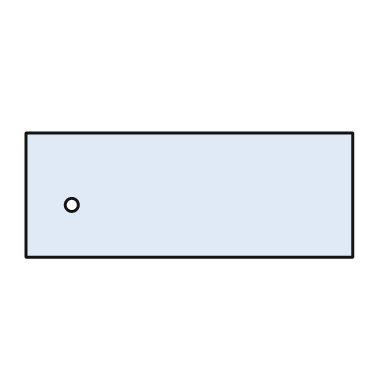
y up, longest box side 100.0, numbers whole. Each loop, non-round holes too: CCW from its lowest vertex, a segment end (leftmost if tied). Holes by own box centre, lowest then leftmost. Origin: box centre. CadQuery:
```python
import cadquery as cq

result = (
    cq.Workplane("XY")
    .moveTo(-50.0, -19.0)
    .lineTo(50.0, -19.0)
    .lineTo(50.0, 19.0)
    .lineTo(-50.0, 19.0)
    .close()
    .moveTo(-36.0, -3.0)
    .circle(2.0)
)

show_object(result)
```